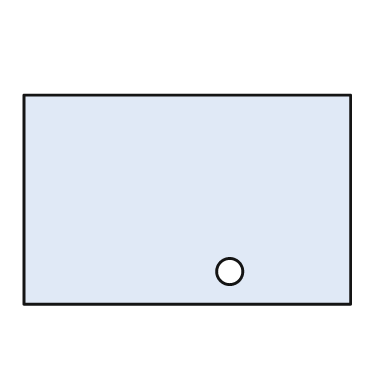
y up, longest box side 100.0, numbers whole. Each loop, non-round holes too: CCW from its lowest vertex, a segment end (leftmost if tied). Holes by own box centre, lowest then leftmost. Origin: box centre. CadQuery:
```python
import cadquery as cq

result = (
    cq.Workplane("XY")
    .moveTo(-50.0, -32.0)
    .lineTo(50.0, -32.0)
    .lineTo(50.0, 32.0)
    .lineTo(-50.0, 32.0)
    .close()
    .moveTo(13.0, -22.0)
    .circle(4.0)
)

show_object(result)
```